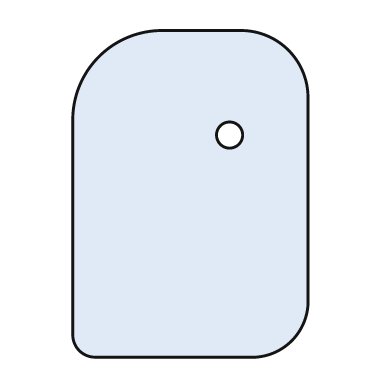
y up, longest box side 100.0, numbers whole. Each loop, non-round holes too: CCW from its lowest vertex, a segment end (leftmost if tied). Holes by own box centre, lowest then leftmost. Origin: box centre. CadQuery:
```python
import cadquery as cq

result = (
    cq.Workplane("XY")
    .moveTo(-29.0, -50.0)
    .lineTo(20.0, -50.0)
    .threePointArc((31.0, -45.0), (36.0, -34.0))
    .lineTo(36.0, 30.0)
    .threePointArc((30.0, 44.0), (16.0, 50.0))
    .lineTo(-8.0, 50.0)
    .threePointArc((-28.0, 42.0), (-36.0, 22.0))
    .lineTo(-36.0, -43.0)
    .threePointArc((-34.0, -48.0), (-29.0, -50.0))
    .close()
    .moveTo(12.0, 18.0)
    .circle(4.0)
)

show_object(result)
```